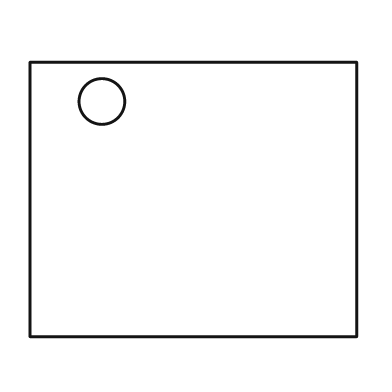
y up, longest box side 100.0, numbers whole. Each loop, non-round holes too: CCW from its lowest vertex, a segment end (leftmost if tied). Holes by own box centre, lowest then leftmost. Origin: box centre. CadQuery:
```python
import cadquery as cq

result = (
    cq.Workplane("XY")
    .moveTo(-50.0, -42.0)
    .lineTo(50.0, -42.0)
    .lineTo(50.0, 42.0)
    .lineTo(-50.0, 42.0)
    .close()
    .moveTo(-28.0, 30.0)
    .circle(7.0)
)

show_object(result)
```